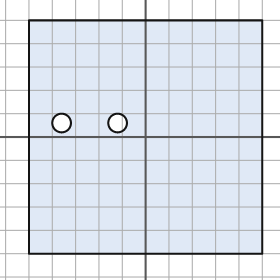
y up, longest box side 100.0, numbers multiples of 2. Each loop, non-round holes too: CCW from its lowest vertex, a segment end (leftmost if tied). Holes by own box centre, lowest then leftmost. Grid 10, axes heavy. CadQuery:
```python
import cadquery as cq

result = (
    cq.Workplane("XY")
    .moveTo(-50.0, -50.0)
    .lineTo(50.0, -50.0)
    .lineTo(50.0, 50.0)
    .lineTo(-50.0, 50.0)
    .close()
    .moveTo(-36.0, 6.0)
    .circle(4.0)
    .moveTo(-12.0, 6.0)
    .circle(4.0)
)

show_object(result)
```